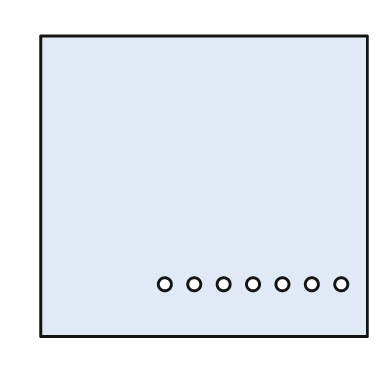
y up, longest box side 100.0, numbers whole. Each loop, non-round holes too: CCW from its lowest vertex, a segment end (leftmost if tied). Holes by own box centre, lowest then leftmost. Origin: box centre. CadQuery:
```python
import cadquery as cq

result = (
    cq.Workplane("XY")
    .moveTo(-50.0, -46.0)
    .lineTo(50.0, -46.0)
    .lineTo(50.0, 46.0)
    .lineTo(-50.0, 46.0)
    .close()
    .moveTo(-12.0, -30.0)
    .circle(2.0)
    .moveTo(-3.0, -30.0)
    .circle(2.0)
    .moveTo(6.0, -30.0)
    .circle(2.0)
    .moveTo(15.0, -30.0)
    .circle(2.0)
    .moveTo(24.0, -30.0)
    .circle(2.0)
    .moveTo(33.0, -30.0)
    .circle(2.0)
    .moveTo(42.0, -30.0)
    .circle(2.0)
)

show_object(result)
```